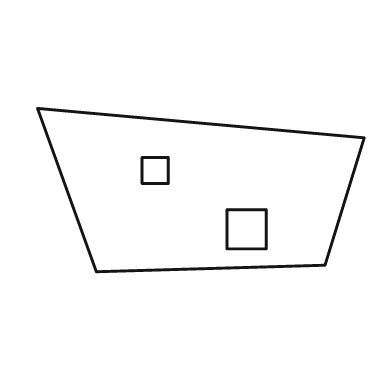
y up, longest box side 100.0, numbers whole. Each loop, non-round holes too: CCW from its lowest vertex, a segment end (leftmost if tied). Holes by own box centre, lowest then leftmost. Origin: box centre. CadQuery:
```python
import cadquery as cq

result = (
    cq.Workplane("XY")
    .moveTo(-32.0, -25.0)
    .lineTo(38.0, -23.0)
    .lineTo(50.0, 16.0)
    .lineTo(-50.0, 25.0)
    .close()
    .moveTo(8.0, -18.0)
    .lineTo(20.0, -18.0)
    .lineTo(20.0, -6.0)
    .lineTo(8.0, -6.0)
    .close()
    .moveTo(-18.0, 2.0)
    .lineTo(-10.0, 2.0)
    .lineTo(-10.0, 10.0)
    .lineTo(-18.0, 10.0)
    .close()
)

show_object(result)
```